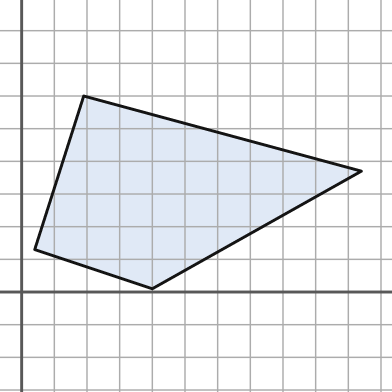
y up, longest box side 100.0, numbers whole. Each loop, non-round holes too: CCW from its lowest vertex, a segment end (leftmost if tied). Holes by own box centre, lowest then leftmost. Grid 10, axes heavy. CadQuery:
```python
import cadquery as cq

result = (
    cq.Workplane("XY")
    .moveTo(40.0, 1.0)
    .lineTo(104.0, 37.0)
    .lineTo(19.0, 60.0)
    .lineTo(4.0, 13.0)
    .close()
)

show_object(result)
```